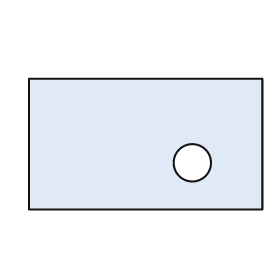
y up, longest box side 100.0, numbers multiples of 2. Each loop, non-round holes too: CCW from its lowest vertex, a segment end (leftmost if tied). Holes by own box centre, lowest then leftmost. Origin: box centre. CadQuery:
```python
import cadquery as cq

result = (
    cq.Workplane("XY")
    .moveTo(-50.0, -28.0)
    .lineTo(50.0, -28.0)
    .lineTo(50.0, 28.0)
    .lineTo(-50.0, 28.0)
    .close()
    .moveTo(20.0, -8.0)
    .circle(8.0)
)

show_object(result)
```